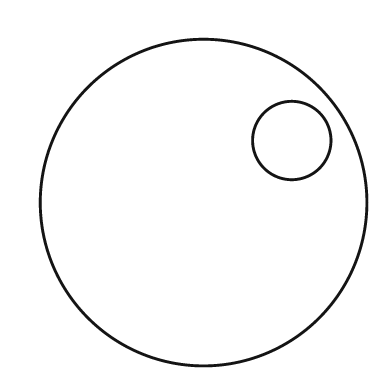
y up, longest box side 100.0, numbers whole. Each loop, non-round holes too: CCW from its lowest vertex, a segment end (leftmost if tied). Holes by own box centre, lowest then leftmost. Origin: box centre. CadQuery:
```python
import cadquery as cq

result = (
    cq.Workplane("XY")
    .moveTo(0.0, 0.0)
    .circle(50.0)
    .moveTo(27.0, 19.0)
    .circle(12.0)
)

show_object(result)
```